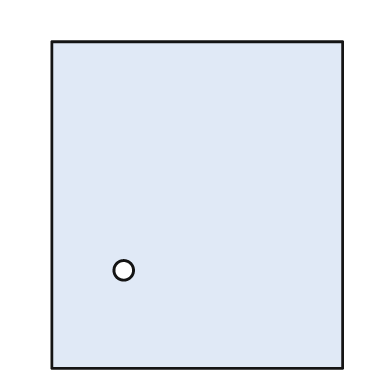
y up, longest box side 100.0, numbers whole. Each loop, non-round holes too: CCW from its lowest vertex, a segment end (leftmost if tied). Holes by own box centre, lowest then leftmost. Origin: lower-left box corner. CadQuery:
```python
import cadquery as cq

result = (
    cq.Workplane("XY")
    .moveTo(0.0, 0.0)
    .lineTo(89.0, 0.0)
    .lineTo(89.0, 100.0)
    .lineTo(0.0, 100.0)
    .close()
    .moveTo(22.0, 30.0)
    .circle(3.0)
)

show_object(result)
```